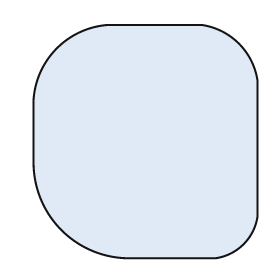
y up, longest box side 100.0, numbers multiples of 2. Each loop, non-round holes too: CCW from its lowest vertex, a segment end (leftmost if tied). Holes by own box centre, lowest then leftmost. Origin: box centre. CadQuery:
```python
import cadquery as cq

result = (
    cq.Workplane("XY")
    .moveTo(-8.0, -50.0)
    .lineTo(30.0, -50.0)
    .threePointArc((42.0, -44.0), (48.0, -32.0))
    .lineTo(48.0, 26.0)
    .threePointArc((40.0, 42.0), (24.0, 50.0))
    .lineTo(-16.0, 50.0)
    .threePointArc((-38.0, 40.0), (-48.0, 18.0))
    .lineTo(-48.0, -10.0)
    .threePointArc((-36.0, -38.0), (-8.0, -50.0))
    .close()
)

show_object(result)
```